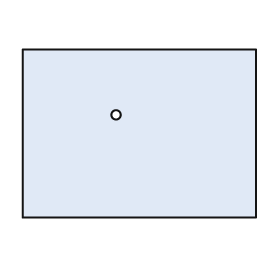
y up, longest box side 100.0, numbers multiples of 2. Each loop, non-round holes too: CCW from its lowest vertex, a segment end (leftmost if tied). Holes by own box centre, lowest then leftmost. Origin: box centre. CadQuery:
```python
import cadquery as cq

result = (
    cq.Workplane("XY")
    .moveTo(-50.0, -36.0)
    .lineTo(50.0, -36.0)
    .lineTo(50.0, 36.0)
    .lineTo(-50.0, 36.0)
    .close()
    .moveTo(-10.0, 8.0)
    .circle(2.0)
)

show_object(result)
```